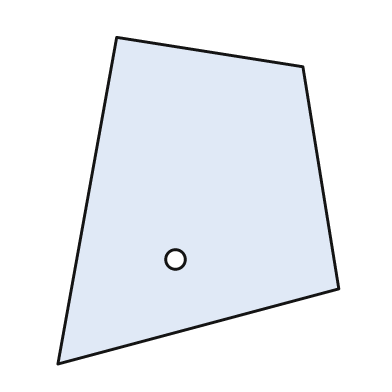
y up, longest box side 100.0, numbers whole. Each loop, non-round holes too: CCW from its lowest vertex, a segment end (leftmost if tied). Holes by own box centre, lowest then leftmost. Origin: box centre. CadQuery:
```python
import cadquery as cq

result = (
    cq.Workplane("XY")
    .moveTo(-43.0, -50.0)
    .lineTo(43.0, -27.0)
    .lineTo(32.0, 41.0)
    .lineTo(-25.0, 50.0)
    .close()
    .moveTo(-7.0, -18.0)
    .circle(3.0)
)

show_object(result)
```